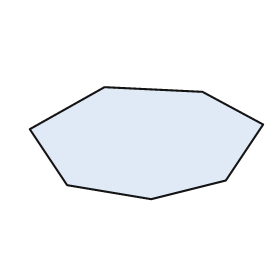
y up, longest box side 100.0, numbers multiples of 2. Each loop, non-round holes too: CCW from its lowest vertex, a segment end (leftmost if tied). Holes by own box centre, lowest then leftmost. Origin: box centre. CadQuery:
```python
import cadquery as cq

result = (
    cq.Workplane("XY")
    .moveTo(2.0, -24.0)
    .lineTo(34.0, -16.0)
    .lineTo(50.0, 8.0)
    .lineTo(24.0, 22.0)
    .lineTo(-18.0, 24.0)
    .lineTo(-50.0, 6.0)
    .lineTo(-34.0, -18.0)
    .close()
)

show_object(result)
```